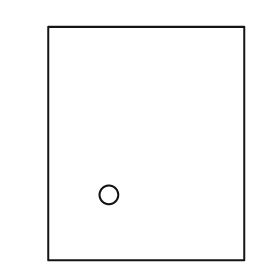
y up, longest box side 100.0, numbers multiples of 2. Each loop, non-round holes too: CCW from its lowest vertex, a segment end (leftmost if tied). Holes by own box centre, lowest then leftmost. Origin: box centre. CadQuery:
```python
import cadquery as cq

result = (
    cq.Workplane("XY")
    .moveTo(-42.0, -50.0)
    .lineTo(42.0, -50.0)
    .lineTo(42.0, 50.0)
    .lineTo(-42.0, 50.0)
    .close()
    .moveTo(-16.0, -22.0)
    .circle(4.0)
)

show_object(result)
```